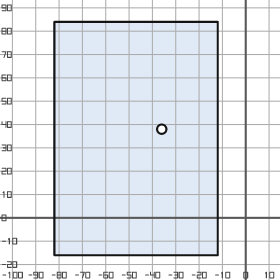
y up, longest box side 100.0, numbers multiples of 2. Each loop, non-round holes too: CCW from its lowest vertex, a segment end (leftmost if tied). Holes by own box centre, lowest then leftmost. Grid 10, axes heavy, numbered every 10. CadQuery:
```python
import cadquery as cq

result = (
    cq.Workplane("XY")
    .moveTo(-82.0, -16.0)
    .lineTo(-12.0, -16.0)
    .lineTo(-12.0, 84.0)
    .lineTo(-82.0, 84.0)
    .close()
    .moveTo(-36.0, 38.0)
    .circle(2.0)
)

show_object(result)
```